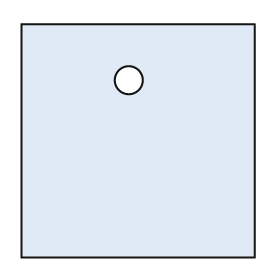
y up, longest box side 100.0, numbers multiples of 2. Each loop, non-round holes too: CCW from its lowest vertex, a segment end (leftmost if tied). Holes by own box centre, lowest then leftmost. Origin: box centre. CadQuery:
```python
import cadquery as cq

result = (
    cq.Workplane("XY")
    .moveTo(-50.0, -50.0)
    .lineTo(50.0, -50.0)
    .lineTo(50.0, 50.0)
    .lineTo(-50.0, 50.0)
    .close()
    .moveTo(-4.0, 26.0)
    .circle(6.0)
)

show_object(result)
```